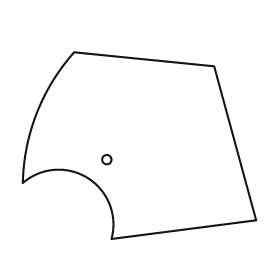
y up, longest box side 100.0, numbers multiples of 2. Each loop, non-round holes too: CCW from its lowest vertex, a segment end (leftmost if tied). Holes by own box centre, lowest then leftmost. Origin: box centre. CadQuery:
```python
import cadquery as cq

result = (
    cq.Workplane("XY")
    .moveTo(-12.0, -40.0)
    .lineTo(50.0, -32.0)
    .lineTo(32.0, 34.0)
    .lineTo(-28.0, 40.0)
    .threePointArc((-44.0, 14.0), (-50.0, -16.0))
    .threePointArc((-22.0, -14.0), (-12.0, -40.0))
    .close()
    .moveTo(-14.0, -6.0)
    .circle(2.0)
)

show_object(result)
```